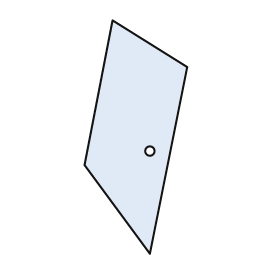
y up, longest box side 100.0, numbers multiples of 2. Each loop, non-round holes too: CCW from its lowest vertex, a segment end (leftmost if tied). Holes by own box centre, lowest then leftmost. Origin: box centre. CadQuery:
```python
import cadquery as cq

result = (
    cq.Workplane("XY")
    .moveTo(6.0, -50.0)
    .lineTo(22.0, 30.0)
    .lineTo(-10.0, 50.0)
    .lineTo(-22.0, -12.0)
    .close()
    .moveTo(6.0, -6.0)
    .circle(2.0)
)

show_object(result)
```